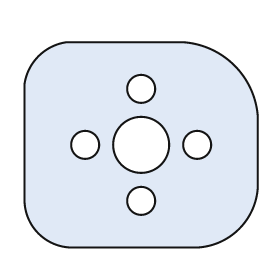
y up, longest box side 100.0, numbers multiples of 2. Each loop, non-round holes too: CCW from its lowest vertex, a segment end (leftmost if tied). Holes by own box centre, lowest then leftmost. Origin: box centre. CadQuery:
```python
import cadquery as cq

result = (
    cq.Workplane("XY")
    .moveTo(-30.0, -44.0)
    .lineTo(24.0, -44.0)
    .threePointArc((42.0, -36.0), (50.0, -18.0))
    .lineTo(50.0, 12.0)
    .threePointArc((40.0, 34.0), (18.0, 44.0))
    .lineTo(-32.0, 44.0)
    .threePointArc((-44.0, 38.0), (-50.0, 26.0))
    .lineTo(-50.0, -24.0)
    .threePointArc((-44.0, -38.0), (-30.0, -44.0))
    .close()
    .moveTo(0.0, -24.0)
    .circle(6.0)
    .moveTo(-24.0, 0.0)
    .circle(6.0)
    .moveTo(0.0, 0.0)
    .circle(12.0)
    .moveTo(24.0, 0.0)
    .circle(6.0)
    .moveTo(0.0, 24.0)
    .circle(6.0)
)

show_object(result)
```